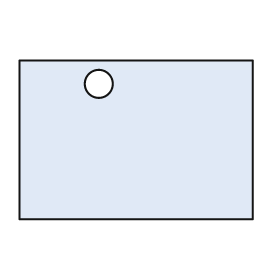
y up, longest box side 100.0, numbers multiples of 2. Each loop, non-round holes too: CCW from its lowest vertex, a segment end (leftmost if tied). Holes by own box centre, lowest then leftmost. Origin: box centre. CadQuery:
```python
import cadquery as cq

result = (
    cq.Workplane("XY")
    .moveTo(-50.0, -34.0)
    .lineTo(50.0, -34.0)
    .lineTo(50.0, 34.0)
    .lineTo(-50.0, 34.0)
    .close()
    .moveTo(-16.0, 24.0)
    .circle(6.0)
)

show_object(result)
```